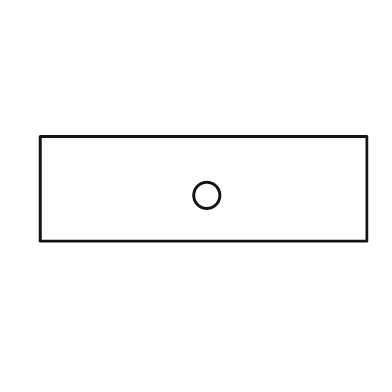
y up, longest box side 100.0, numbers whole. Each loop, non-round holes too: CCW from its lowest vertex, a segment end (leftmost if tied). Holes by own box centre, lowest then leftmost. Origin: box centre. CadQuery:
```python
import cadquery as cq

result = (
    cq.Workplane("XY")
    .moveTo(-50.0, -16.0)
    .lineTo(50.0, -16.0)
    .lineTo(50.0, 16.0)
    .lineTo(-50.0, 16.0)
    .close()
    .moveTo(1.0, -2.0)
    .circle(4.0)
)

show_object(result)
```